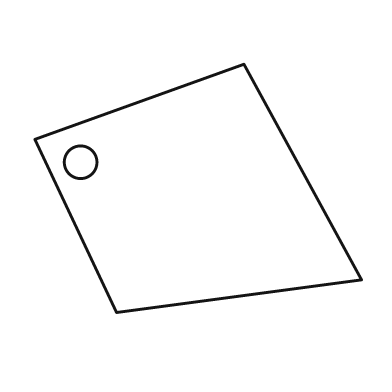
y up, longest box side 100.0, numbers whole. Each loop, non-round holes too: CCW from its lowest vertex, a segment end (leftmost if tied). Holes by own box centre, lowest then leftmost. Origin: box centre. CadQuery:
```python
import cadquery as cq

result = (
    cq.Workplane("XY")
    .moveTo(-25.0, -38.0)
    .lineTo(50.0, -28.0)
    .lineTo(14.0, 38.0)
    .lineTo(-50.0, 15.0)
    .close()
    .moveTo(-36.0, 8.0)
    .circle(5.0)
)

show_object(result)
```